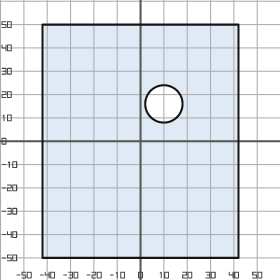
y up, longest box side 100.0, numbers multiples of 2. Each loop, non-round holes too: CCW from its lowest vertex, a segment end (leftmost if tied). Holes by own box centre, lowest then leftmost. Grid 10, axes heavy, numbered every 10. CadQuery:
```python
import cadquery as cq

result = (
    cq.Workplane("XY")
    .moveTo(-42.0, -50.0)
    .lineTo(42.0, -50.0)
    .lineTo(42.0, 50.0)
    .lineTo(-42.0, 50.0)
    .close()
    .moveTo(10.0, 16.0)
    .circle(8.0)
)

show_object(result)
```